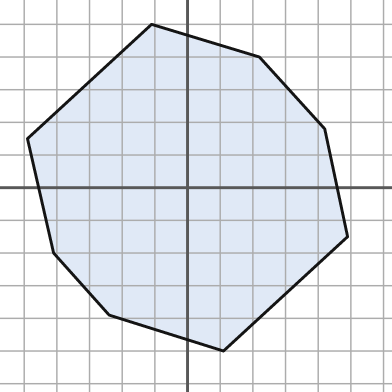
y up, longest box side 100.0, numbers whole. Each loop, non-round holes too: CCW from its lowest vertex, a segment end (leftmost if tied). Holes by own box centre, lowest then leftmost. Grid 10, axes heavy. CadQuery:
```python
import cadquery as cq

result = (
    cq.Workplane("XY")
    .moveTo(11.0, -50.0)
    .lineTo(49.0, -15.0)
    .lineTo(42.0, 18.0)
    .lineTo(22.0, 40.0)
    .lineTo(-11.0, 50.0)
    .lineTo(-49.0, 15.0)
    .lineTo(-41.0, -20.0)
    .lineTo(-24.0, -39.0)
    .close()
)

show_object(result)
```